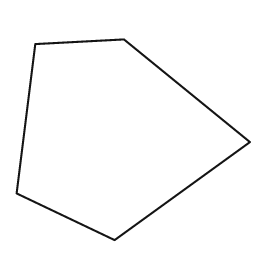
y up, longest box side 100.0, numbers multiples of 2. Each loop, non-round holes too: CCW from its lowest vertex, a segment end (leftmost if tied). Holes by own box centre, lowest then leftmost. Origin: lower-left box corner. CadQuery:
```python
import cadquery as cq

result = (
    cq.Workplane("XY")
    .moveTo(42.0, 0.0)
    .lineTo(100.0, 42.0)
    .lineTo(46.0, 86.0)
    .lineTo(8.0, 84.0)
    .lineTo(0.0, 20.0)
    .close()
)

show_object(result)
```